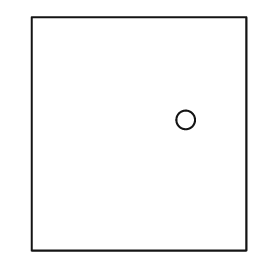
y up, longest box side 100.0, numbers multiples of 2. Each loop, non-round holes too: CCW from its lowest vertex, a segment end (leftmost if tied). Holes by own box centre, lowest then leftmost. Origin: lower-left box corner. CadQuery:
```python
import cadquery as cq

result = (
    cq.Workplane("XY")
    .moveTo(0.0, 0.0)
    .lineTo(92.0, 0.0)
    .lineTo(92.0, 100.0)
    .lineTo(0.0, 100.0)
    .close()
    .moveTo(66.0, 56.0)
    .circle(4.0)
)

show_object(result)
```